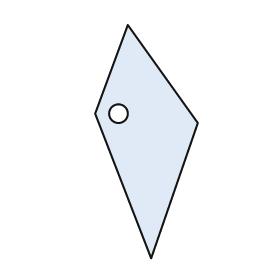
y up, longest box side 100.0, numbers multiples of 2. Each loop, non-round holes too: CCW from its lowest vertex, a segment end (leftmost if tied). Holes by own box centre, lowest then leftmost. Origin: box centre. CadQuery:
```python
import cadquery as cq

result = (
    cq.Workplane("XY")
    .moveTo(2.0, -50.0)
    .lineTo(22.0, 8.0)
    .lineTo(-8.0, 50.0)
    .lineTo(-22.0, 12.0)
    .close()
    .moveTo(-12.0, 12.0)
    .circle(4.0)
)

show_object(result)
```